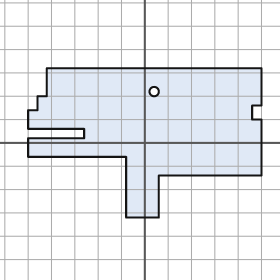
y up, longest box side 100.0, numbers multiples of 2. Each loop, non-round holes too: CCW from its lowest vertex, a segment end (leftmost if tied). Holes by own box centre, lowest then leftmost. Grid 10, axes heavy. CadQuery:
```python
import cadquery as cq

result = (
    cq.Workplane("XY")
    .moveTo(-8.0, -32.0)
    .lineTo(6.0, -32.0)
    .lineTo(6.0, -14.0)
    .lineTo(50.0, -14.0)
    .lineTo(50.0, 10.0)
    .lineTo(46.0, 10.0)
    .lineTo(46.0, 16.0)
    .lineTo(50.0, 16.0)
    .lineTo(50.0, 32.0)
    .lineTo(-42.0, 32.0)
    .lineTo(-42.0, 20.0)
    .lineTo(-46.0, 20.0)
    .lineTo(-46.0, 14.0)
    .lineTo(-50.0, 14.0)
    .lineTo(-50.0, 6.0)
    .lineTo(-26.0, 6.0)
    .lineTo(-26.0, 2.0)
    .lineTo(-50.0, 2.0)
    .lineTo(-50.0, -6.0)
    .lineTo(-8.0, -6.0)
    .close()
    .moveTo(4.0, 22.0)
    .circle(2.0)
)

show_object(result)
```